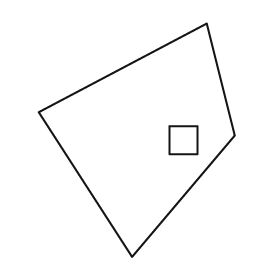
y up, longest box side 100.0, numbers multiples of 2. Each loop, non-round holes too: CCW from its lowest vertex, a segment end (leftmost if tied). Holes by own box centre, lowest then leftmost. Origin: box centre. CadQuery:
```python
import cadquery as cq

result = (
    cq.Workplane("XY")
    .moveTo(-2.0, -50.0)
    .lineTo(42.0, 2.0)
    .lineTo(30.0, 50.0)
    .lineTo(-42.0, 12.0)
    .close()
    .moveTo(14.0, -6.0)
    .lineTo(26.0, -6.0)
    .lineTo(26.0, 6.0)
    .lineTo(14.0, 6.0)
    .close()
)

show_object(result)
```